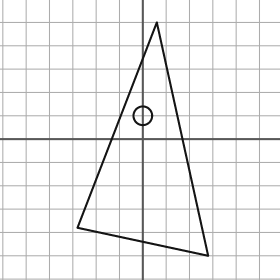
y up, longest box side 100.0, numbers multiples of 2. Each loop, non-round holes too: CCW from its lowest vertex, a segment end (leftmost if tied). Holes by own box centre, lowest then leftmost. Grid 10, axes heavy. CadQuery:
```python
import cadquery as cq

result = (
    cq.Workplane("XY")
    .moveTo(28.0, -50.0)
    .lineTo(6.0, 50.0)
    .lineTo(-28.0, -38.0)
    .close()
    .moveTo(0.0, 10.0)
    .circle(4.0)
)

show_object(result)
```